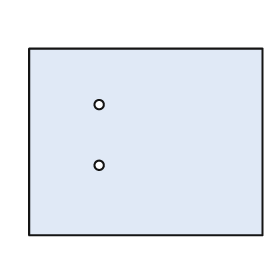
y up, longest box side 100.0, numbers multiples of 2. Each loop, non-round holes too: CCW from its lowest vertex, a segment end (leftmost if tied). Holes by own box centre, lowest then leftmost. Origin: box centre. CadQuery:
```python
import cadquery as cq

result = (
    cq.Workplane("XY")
    .moveTo(-50.0, -40.0)
    .lineTo(50.0, -40.0)
    .lineTo(50.0, 40.0)
    .lineTo(-50.0, 40.0)
    .close()
    .moveTo(-20.0, -10.0)
    .circle(2.0)
    .moveTo(-20.0, 16.0)
    .circle(2.0)
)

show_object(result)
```